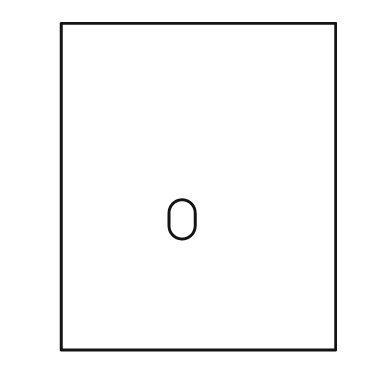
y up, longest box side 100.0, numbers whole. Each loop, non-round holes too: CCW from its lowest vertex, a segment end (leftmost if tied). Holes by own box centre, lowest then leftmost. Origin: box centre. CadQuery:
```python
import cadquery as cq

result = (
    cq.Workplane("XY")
    .moveTo(-42.0, -50.0)
    .lineTo(42.0, -50.0)
    .lineTo(42.0, 50.0)
    .lineTo(-42.0, 50.0)
    .close()
    .moveTo(-9.0, -12.0)
    .threePointArc((-5.0, -16.0), (-1.0, -12.0))
    .lineTo(-1.0, -8.0)
    .threePointArc((-5.0, -4.0), (-9.0, -8.0))
    .close()
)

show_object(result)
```